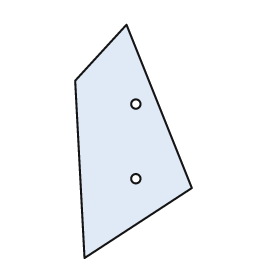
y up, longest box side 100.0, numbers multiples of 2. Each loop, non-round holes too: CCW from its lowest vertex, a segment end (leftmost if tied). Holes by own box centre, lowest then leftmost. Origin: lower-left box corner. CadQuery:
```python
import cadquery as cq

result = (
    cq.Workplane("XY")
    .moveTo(4.0, 0.0)
    .lineTo(50.0, 30.0)
    .lineTo(22.0, 100.0)
    .lineTo(0.0, 76.0)
    .close()
    .moveTo(26.0, 34.0)
    .circle(2.0)
    .moveTo(26.0, 66.0)
    .circle(2.0)
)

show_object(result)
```